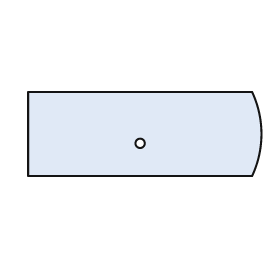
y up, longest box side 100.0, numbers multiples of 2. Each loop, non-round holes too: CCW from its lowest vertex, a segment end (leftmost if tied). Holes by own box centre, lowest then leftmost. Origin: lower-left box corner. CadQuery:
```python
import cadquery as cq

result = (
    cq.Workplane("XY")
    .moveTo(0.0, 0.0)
    .lineTo(96.0, 0.0)
    .threePointArc((100.0, 18.0), (96.0, 36.0))
    .lineTo(0.0, 36.0)
    .close()
    .moveTo(48.0, 14.0)
    .circle(2.0)
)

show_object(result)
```